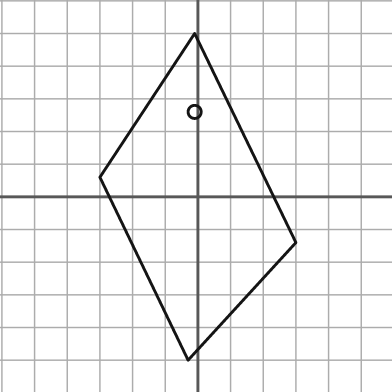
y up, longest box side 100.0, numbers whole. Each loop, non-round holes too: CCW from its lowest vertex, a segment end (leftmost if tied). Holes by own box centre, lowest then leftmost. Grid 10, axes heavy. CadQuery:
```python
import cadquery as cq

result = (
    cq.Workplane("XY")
    .moveTo(-3.0, -50.0)
    .lineTo(30.0, -14.0)
    .lineTo(-1.0, 50.0)
    .lineTo(-30.0, 6.0)
    .close()
    .moveTo(-1.0, 26.0)
    .circle(2.0)
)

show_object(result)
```